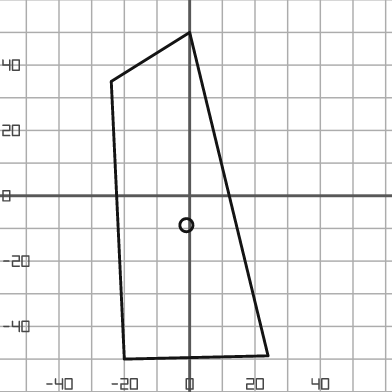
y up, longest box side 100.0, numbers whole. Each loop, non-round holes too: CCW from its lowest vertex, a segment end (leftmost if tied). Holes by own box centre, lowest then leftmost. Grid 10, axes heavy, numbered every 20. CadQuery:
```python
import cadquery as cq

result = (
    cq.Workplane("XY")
    .moveTo(-20.0, -50.0)
    .lineTo(24.0, -49.0)
    .lineTo(0.0, 50.0)
    .lineTo(-24.0, 35.0)
    .close()
    .moveTo(-1.0, -9.0)
    .circle(2.0)
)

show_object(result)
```